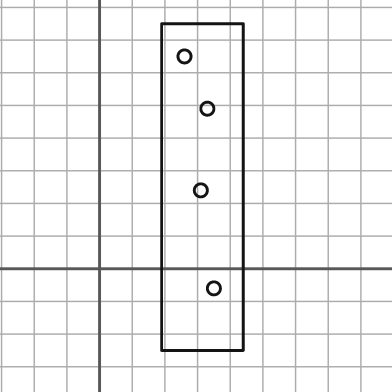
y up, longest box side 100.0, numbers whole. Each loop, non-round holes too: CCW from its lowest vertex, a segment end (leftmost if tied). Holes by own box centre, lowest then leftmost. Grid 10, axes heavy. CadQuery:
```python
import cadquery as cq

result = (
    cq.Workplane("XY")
    .moveTo(19.0, -25.0)
    .lineTo(44.0, -25.0)
    .lineTo(44.0, 75.0)
    .lineTo(19.0, 75.0)
    .close()
    .moveTo(35.0, -6.0)
    .circle(2.0)
    .moveTo(31.0, 24.0)
    .circle(2.0)
    .moveTo(33.0, 49.0)
    .circle(2.0)
    .moveTo(26.0, 65.0)
    .circle(2.0)
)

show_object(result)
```